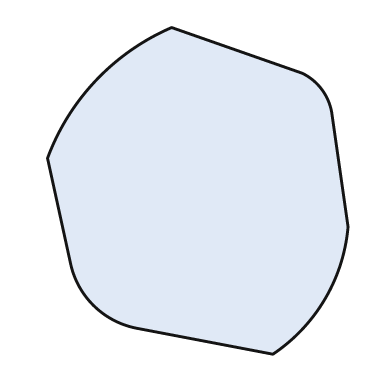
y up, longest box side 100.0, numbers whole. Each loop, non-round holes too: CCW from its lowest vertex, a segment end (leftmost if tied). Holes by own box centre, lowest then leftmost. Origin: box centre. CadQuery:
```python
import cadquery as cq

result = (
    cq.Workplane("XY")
    .moveTo(23.0, -50.0)
    .threePointArc((39.0, -33.0), (46.0, -11.0))
    .lineTo(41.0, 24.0)
    .threePointArc((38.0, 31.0), (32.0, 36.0))
    .lineTo(-8.0, 50.0)
    .threePointArc((-31.0, 34.0), (-46.0, 10.0))
    .lineTo(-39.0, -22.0)
    .threePointArc((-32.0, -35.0), (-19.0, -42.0))
    .close()
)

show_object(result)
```